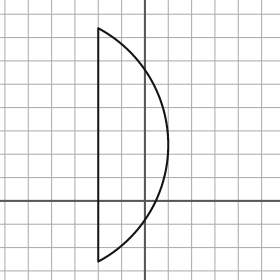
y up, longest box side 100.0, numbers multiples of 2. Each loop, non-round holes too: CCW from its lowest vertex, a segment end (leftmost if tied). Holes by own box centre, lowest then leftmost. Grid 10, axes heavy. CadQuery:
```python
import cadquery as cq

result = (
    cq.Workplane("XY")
    .moveTo(-20.0, -26.0)
    .threePointArc((10.0, 24.0), (-20.0, 74.0))
    .close()
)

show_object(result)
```